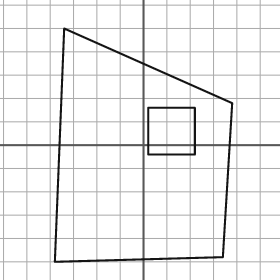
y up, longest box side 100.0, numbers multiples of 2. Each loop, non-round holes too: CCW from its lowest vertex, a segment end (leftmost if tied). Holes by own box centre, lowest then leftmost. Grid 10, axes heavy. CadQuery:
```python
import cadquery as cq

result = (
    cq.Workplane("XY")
    .moveTo(-38.0, -50.0)
    .lineTo(34.0, -48.0)
    .lineTo(38.0, 18.0)
    .lineTo(-34.0, 50.0)
    .close()
    .moveTo(2.0, -4.0)
    .lineTo(22.0, -4.0)
    .lineTo(22.0, 16.0)
    .lineTo(2.0, 16.0)
    .close()
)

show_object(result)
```